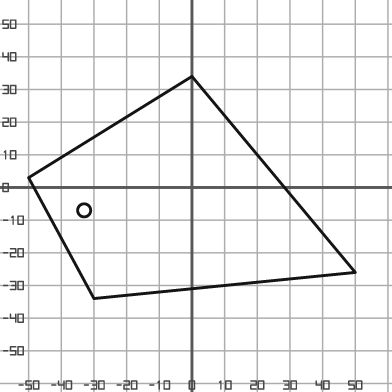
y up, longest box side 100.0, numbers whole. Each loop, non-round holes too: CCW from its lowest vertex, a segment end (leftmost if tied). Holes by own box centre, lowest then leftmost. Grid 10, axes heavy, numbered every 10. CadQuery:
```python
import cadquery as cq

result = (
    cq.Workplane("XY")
    .moveTo(-30.0, -34.0)
    .lineTo(50.0, -26.0)
    .lineTo(0.0, 34.0)
    .lineTo(-50.0, 3.0)
    .close()
    .moveTo(-33.0, -7.0)
    .circle(2.0)
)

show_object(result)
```